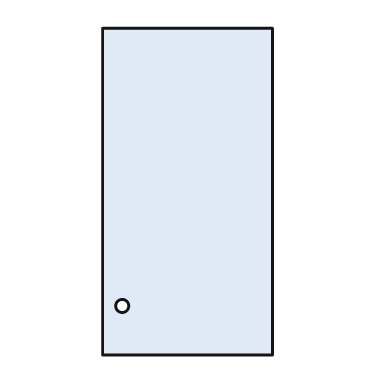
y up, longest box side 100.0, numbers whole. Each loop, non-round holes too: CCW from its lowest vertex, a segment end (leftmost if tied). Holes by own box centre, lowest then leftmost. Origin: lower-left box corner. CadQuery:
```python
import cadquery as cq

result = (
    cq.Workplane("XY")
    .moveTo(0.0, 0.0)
    .lineTo(52.0, 0.0)
    .lineTo(52.0, 100.0)
    .lineTo(0.0, 100.0)
    .close()
    .moveTo(6.0, 15.0)
    .circle(2.0)
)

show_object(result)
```